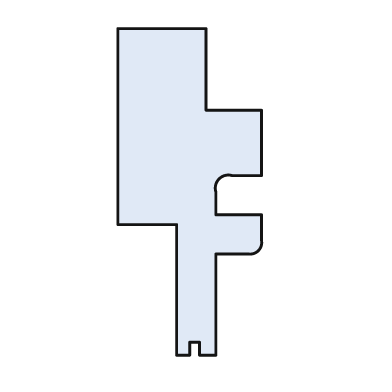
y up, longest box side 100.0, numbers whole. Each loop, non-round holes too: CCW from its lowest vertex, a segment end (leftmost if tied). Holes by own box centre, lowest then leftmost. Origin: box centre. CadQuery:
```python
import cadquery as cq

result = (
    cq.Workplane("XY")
    .moveTo(-4.0, -50.0)
    .lineTo(0.0, -50.0)
    .lineTo(0.0, -46.0)
    .lineTo(3.0, -46.0)
    .lineTo(3.0, -50.0)
    .lineTo(8.0, -50.0)
    .lineTo(8.0, -19.0)
    .lineTo(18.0, -19.0)
    .threePointArc((21.0, -18.0), (22.0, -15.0))
    .lineTo(22.0, -7.0)
    .lineTo(8.0, -7.0)
    .lineTo(8.0, 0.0)
    .threePointArc((9.0, 4.0), (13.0, 5.0))
    .lineTo(22.0, 5.0)
    .lineTo(22.0, 25.0)
    .lineTo(5.0, 25.0)
    .lineTo(5.0, 50.0)
    .lineTo(-22.0, 50.0)
    .lineTo(-22.0, -10.0)
    .lineTo(-4.0, -10.0)
    .close()
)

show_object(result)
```